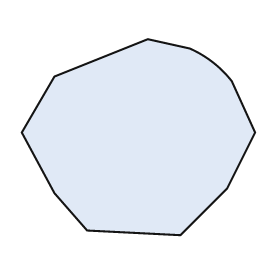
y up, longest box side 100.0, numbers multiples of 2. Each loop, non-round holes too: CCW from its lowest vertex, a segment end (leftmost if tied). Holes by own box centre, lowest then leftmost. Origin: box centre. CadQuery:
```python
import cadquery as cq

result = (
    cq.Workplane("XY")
    .moveTo(18.0, -42.0)
    .lineTo(38.0, -22.0)
    .lineTo(50.0, 2.0)
    .lineTo(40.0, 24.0)
    .threePointArc((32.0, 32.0), (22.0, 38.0))
    .lineTo(4.0, 42.0)
    .lineTo(-36.0, 26.0)
    .lineTo(-50.0, 2.0)
    .lineTo(-36.0, -24.0)
    .lineTo(-22.0, -40.0)
    .close()
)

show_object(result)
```